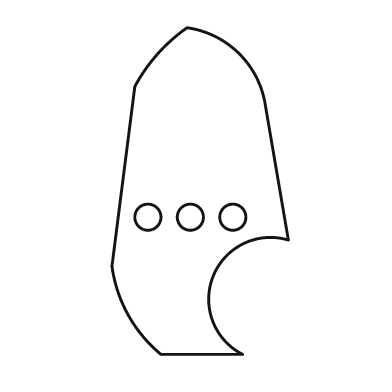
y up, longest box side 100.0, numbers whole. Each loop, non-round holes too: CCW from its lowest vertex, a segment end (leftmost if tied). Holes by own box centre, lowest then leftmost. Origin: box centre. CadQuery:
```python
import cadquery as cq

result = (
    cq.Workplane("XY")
    .moveTo(-12.0, -50.0)
    .lineTo(13.0, -50.0)
    .threePointArc((4.0, -26.0), (27.0, -15.0))
    .lineTo(20.0, 26.0)
    .threePointArc((12.0, 42.0), (-4.0, 50.0))
    .threePointArc((-13.0, 42.0), (-20.0, 32.0))
    .lineTo(-27.0, -23.0)
    .threePointArc((-22.0, -38.0), (-12.0, -50.0))
    .close()
    .moveTo(-16.0, -8.0)
    .circle(4.0)
    .moveTo(-3.0, -8.0)
    .circle(4.0)
    .moveTo(10.0, -8.0)
    .circle(4.0)
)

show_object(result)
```